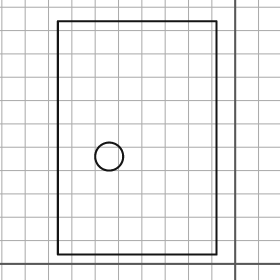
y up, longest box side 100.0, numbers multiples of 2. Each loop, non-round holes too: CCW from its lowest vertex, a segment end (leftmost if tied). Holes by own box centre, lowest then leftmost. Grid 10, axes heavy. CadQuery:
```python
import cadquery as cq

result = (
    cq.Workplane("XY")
    .moveTo(-76.0, 4.0)
    .lineTo(-8.0, 4.0)
    .lineTo(-8.0, 104.0)
    .lineTo(-76.0, 104.0)
    .close()
    .moveTo(-54.0, 46.0)
    .circle(6.0)
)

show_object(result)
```